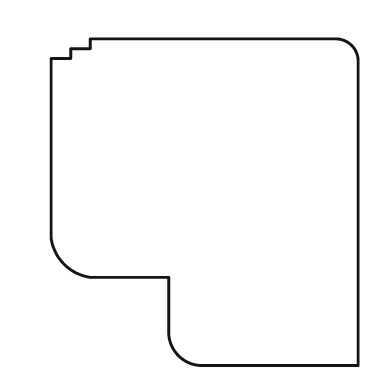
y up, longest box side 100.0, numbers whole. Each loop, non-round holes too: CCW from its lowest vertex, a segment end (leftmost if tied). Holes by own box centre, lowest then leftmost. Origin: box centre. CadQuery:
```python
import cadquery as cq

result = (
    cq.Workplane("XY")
    .moveTo(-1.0, -50.0)
    .lineTo(47.0, -50.0)
    .lineTo(47.0, 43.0)
    .threePointArc((45.0, 48.0), (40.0, 50.0))
    .lineTo(-35.0, 50.0)
    .lineTo(-35.0, 47.0)
    .lineTo(-41.0, 47.0)
    .lineTo(-41.0, 44.0)
    .lineTo(-47.0, 44.0)
    .lineTo(-47.0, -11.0)
    .threePointArc((-43.0, -19.0), (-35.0, -23.0))
    .lineTo(-11.0, -23.0)
    .lineTo(-11.0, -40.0)
    .threePointArc((-8.0, -47.0), (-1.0, -50.0))
    .close()
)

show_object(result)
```